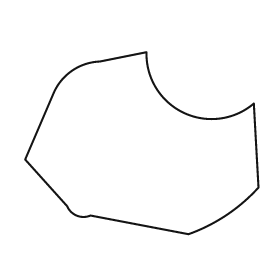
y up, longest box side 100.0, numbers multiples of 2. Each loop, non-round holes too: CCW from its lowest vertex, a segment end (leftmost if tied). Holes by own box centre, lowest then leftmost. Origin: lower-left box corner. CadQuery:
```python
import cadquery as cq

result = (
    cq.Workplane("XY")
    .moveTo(70.0, 0.0)
    .threePointArc((86.0, 8.0), (100.0, 20.0))
    .lineTo(98.0, 56.0)
    .threePointArc((68.0, 52.0), (52.0, 78.0))
    .lineTo(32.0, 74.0)
    .threePointArc((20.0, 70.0), (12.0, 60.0))
    .lineTo(0.0, 32.0)
    .lineTo(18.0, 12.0)
    .threePointArc((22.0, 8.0), (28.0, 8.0))
    .close()
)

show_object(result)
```